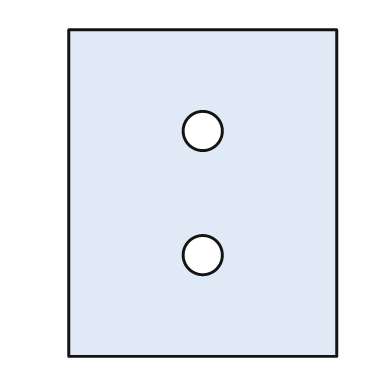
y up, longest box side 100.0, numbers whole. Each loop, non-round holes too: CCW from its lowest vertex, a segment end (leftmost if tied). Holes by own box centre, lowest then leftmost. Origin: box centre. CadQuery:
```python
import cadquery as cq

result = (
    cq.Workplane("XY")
    .moveTo(-41.0, -50.0)
    .lineTo(41.0, -50.0)
    .lineTo(41.0, 50.0)
    .lineTo(-41.0, 50.0)
    .close()
    .moveTo(0.0, -19.0)
    .circle(6.0)
    .moveTo(0.0, 19.0)
    .circle(6.0)
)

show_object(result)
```